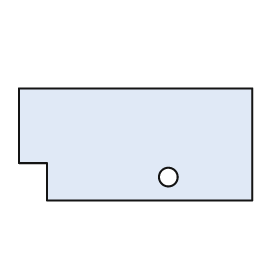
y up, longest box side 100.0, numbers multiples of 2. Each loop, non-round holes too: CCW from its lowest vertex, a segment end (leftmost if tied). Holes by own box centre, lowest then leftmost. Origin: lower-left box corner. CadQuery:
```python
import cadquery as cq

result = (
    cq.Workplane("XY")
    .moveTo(12.0, 0.0)
    .lineTo(100.0, 0.0)
    .lineTo(100.0, 48.0)
    .lineTo(0.0, 48.0)
    .lineTo(0.0, 16.0)
    .lineTo(12.0, 16.0)
    .close()
    .moveTo(64.0, 10.0)
    .circle(4.0)
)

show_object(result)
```